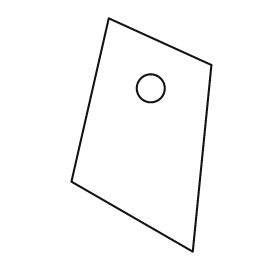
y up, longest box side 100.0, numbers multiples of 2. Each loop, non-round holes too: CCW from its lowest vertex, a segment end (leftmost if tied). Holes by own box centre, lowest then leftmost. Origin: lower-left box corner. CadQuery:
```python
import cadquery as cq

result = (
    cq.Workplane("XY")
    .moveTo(52.0, 0.0)
    .lineTo(60.0, 80.0)
    .lineTo(16.0, 100.0)
    .lineTo(0.0, 30.0)
    .close()
    .moveTo(34.0, 70.0)
    .circle(6.0)
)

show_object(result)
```